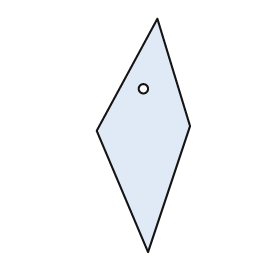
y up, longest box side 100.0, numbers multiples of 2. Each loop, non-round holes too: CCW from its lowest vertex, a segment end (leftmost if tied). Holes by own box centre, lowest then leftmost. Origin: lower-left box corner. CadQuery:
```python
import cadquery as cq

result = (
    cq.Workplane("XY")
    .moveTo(22.0, 0.0)
    .lineTo(40.0, 54.0)
    .lineTo(26.0, 100.0)
    .lineTo(0.0, 52.0)
    .close()
    .moveTo(20.0, 70.0)
    .circle(2.0)
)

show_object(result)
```